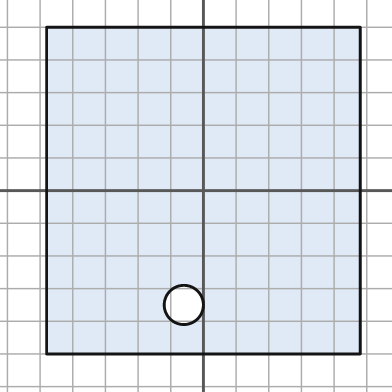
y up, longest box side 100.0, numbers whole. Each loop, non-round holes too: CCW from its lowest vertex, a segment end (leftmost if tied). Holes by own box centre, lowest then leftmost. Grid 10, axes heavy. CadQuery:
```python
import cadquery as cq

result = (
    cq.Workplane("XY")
    .moveTo(-48.0, -50.0)
    .lineTo(48.0, -50.0)
    .lineTo(48.0, 50.0)
    .lineTo(-48.0, 50.0)
    .close()
    .moveTo(-6.0, -35.0)
    .circle(6.0)
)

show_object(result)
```